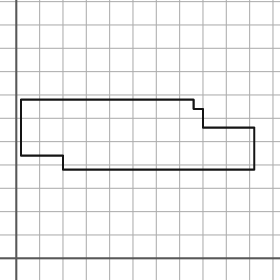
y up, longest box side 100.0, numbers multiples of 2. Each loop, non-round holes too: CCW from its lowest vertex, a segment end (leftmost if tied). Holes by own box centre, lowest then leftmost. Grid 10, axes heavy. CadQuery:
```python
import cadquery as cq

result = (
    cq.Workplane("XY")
    .moveTo(20.0, 38.0)
    .lineTo(102.0, 38.0)
    .lineTo(102.0, 56.0)
    .lineTo(80.0, 56.0)
    .lineTo(80.0, 64.0)
    .lineTo(76.0, 64.0)
    .lineTo(76.0, 68.0)
    .lineTo(2.0, 68.0)
    .lineTo(2.0, 44.0)
    .lineTo(20.0, 44.0)
    .close()
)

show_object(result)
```